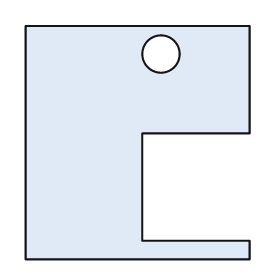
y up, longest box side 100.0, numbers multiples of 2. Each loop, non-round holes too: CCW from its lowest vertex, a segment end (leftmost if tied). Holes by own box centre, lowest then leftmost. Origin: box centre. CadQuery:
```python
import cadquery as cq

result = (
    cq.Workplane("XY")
    .moveTo(-48.0, -50.0)
    .lineTo(48.0, -50.0)
    .lineTo(48.0, -42.0)
    .lineTo(2.0, -42.0)
    .lineTo(2.0, 4.0)
    .lineTo(48.0, 4.0)
    .lineTo(48.0, 50.0)
    .lineTo(-48.0, 50.0)
    .close()
    .moveTo(10.0, 38.0)
    .circle(8.0)
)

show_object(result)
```